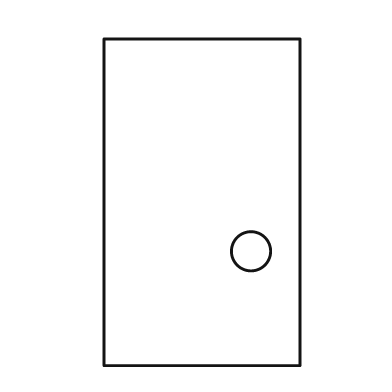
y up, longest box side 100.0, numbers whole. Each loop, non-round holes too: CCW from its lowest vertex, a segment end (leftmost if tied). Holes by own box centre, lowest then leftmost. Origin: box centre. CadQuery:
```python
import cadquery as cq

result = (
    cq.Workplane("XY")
    .moveTo(-30.0, -50.0)
    .lineTo(30.0, -50.0)
    .lineTo(30.0, 50.0)
    .lineTo(-30.0, 50.0)
    .close()
    .moveTo(15.0, -15.0)
    .circle(6.0)
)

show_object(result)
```